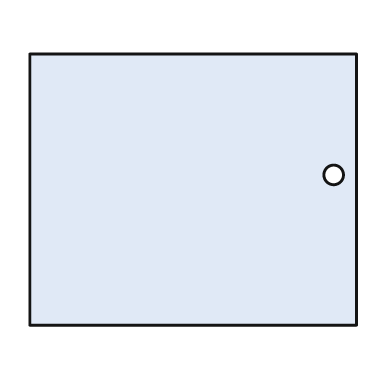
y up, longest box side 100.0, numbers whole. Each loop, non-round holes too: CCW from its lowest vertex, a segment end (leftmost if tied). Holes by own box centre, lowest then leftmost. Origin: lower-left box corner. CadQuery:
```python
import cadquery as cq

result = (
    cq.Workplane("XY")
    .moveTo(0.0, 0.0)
    .lineTo(100.0, 0.0)
    .lineTo(100.0, 83.0)
    .lineTo(0.0, 83.0)
    .close()
    .moveTo(93.0, 46.0)
    .circle(3.0)
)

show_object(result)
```